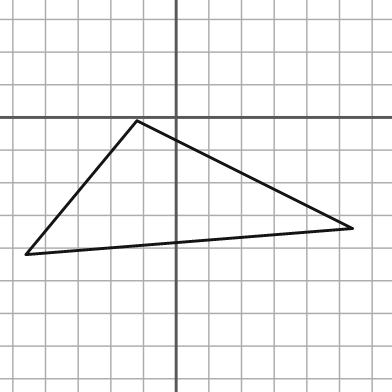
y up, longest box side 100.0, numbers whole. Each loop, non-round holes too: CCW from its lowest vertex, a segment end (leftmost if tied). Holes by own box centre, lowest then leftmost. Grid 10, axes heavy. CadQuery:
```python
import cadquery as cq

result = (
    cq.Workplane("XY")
    .moveTo(-46.0, -42.0)
    .lineTo(54.0, -34.0)
    .lineTo(-12.0, -1.0)
    .close()
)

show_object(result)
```